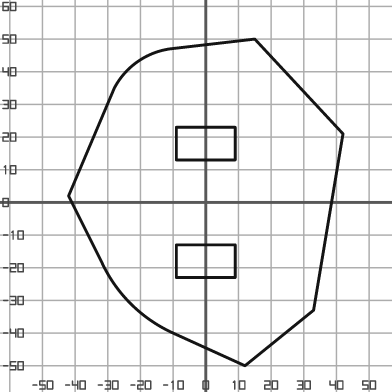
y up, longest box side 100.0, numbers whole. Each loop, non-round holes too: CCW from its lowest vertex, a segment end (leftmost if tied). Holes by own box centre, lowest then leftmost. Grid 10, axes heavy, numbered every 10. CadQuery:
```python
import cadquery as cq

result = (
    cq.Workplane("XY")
    .moveTo(12.0, -50.0)
    .lineTo(33.0, -33.0)
    .lineTo(42.0, 21.0)
    .lineTo(15.0, 50.0)
    .lineTo(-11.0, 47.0)
    .threePointArc((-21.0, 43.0), (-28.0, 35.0))
    .lineTo(-42.0, 2.0)
    .lineTo(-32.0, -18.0)
    .threePointArc((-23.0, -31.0), (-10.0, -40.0))
    .close()
    .moveTo(-9.0, -23.0)
    .lineTo(9.0, -23.0)
    .lineTo(9.0, -13.0)
    .lineTo(-9.0, -13.0)
    .close()
    .moveTo(-9.0, 13.0)
    .lineTo(9.0, 13.0)
    .lineTo(9.0, 23.0)
    .lineTo(-9.0, 23.0)
    .close()
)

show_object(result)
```